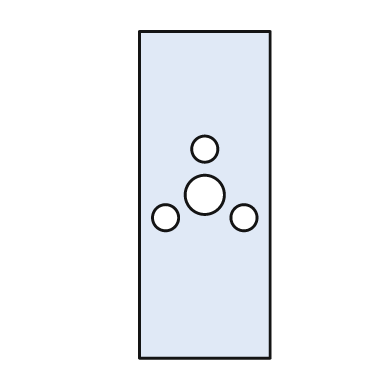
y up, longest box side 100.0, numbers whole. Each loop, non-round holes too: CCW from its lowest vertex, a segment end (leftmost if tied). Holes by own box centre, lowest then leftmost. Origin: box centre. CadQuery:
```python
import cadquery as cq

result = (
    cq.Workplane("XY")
    .moveTo(-20.0, -50.0)
    .lineTo(20.0, -50.0)
    .lineTo(20.0, 50.0)
    .lineTo(-20.0, 50.0)
    .close()
    .moveTo(-12.0, -7.0)
    .circle(4.0)
    .moveTo(12.0, -7.0)
    .circle(4.0)
    .moveTo(0.0, 0.0)
    .circle(6.0)
    .moveTo(0.0, 14.0)
    .circle(4.0)
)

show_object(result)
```